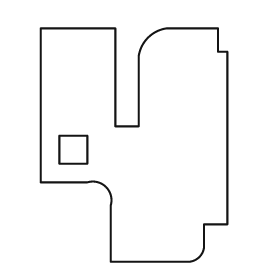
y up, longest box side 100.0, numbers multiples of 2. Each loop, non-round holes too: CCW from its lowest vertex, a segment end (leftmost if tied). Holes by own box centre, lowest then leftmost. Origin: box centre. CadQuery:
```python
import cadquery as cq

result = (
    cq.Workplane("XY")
    .moveTo(-10.0, -50.0)
    .lineTo(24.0, -50.0)
    .threePointArc((28.0, -48.0), (30.0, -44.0))
    .lineTo(30.0, -34.0)
    .lineTo(40.0, -34.0)
    .lineTo(40.0, 40.0)
    .lineTo(36.0, 40.0)
    .lineTo(36.0, 50.0)
    .lineTo(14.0, 50.0)
    .threePointArc((6.0, 46.0), (2.0, 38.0))
    .lineTo(2.0, 8.0)
    .lineTo(-8.0, 8.0)
    .lineTo(-8.0, 50.0)
    .lineTo(-40.0, 50.0)
    .lineTo(-40.0, -16.0)
    .lineTo(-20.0, -16.0)
    .threePointArc((-12.0, -18.0), (-10.0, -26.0))
    .close()
    .moveTo(-32.0, -8.0)
    .lineTo(-20.0, -8.0)
    .lineTo(-20.0, 4.0)
    .lineTo(-32.0, 4.0)
    .close()
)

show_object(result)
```